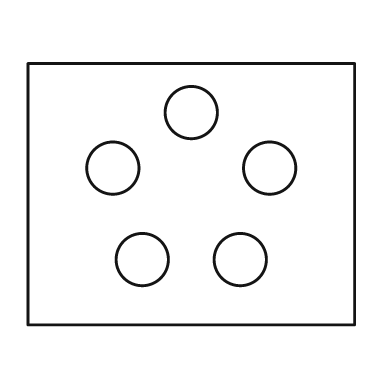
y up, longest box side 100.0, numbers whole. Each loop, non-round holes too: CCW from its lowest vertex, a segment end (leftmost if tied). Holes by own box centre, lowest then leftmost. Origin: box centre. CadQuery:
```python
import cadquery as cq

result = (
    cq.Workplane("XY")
    .moveTo(-50.0, -40.0)
    .lineTo(50.0, -40.0)
    .lineTo(50.0, 40.0)
    .lineTo(-50.0, 40.0)
    .close()
    .moveTo(-15.0, -20.0)
    .circle(8.0)
    .moveTo(15.0, -20.0)
    .circle(8.0)
    .moveTo(-24.0, 8.0)
    .circle(8.0)
    .moveTo(24.0, 8.0)
    .circle(8.0)
    .moveTo(0.0, 25.0)
    .circle(8.0)
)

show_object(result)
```